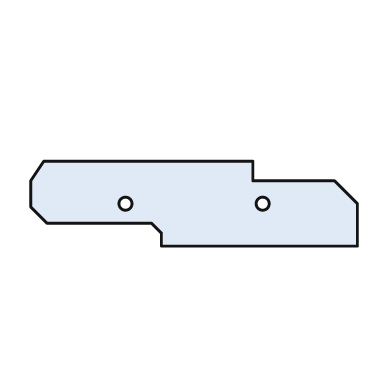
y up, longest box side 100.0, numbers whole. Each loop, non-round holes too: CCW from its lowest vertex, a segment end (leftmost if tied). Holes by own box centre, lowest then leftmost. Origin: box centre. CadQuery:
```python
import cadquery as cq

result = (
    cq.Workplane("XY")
    .moveTo(-10.0, -13.0)
    .lineTo(50.0, -13.0)
    .lineTo(50.0, 0.0)
    .lineTo(43.0, 7.0)
    .lineTo(18.0, 7.0)
    .lineTo(18.0, 13.0)
    .lineTo(-46.0, 13.0)
    .lineTo(-50.0, 7.0)
    .lineTo(-50.0, -1.0)
    .lineTo(-45.0, -6.0)
    .lineTo(-13.0, -6.0)
    .lineTo(-10.0, -9.0)
    .close()
    .moveTo(-21.0, 0.0)
    .circle(2.0)
    .moveTo(21.0, 0.0)
    .circle(2.0)
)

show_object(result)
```